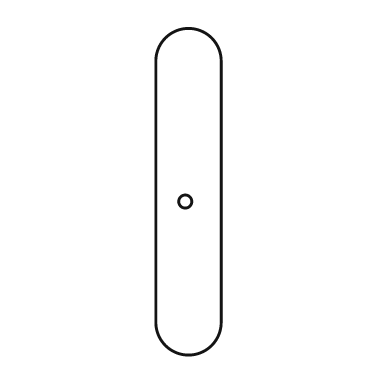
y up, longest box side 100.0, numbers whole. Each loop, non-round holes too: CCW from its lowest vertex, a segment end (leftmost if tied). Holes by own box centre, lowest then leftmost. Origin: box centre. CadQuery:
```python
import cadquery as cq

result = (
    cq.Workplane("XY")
    .moveTo(-10.0, -40.0)
    .threePointArc((0.0, -50.0), (10.0, -40.0))
    .lineTo(10.0, 40.0)
    .threePointArc((0.0, 50.0), (-10.0, 40.0))
    .close()
    .moveTo(-1.0, -3.0)
    .circle(2.0)
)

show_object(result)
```